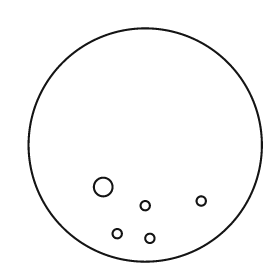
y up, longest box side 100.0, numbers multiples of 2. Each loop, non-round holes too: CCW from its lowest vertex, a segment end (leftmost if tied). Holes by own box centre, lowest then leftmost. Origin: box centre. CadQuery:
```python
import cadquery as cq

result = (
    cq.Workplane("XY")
    .moveTo(0.0, 0.0)
    .circle(50.0)
    .moveTo(2.0, -40.0)
    .circle(2.0)
    .moveTo(-12.0, -38.0)
    .circle(2.0)
    .moveTo(0.0, -26.0)
    .circle(2.0)
    .moveTo(24.0, -24.0)
    .circle(2.0)
    .moveTo(-18.0, -18.0)
    .circle(4.0)
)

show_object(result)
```